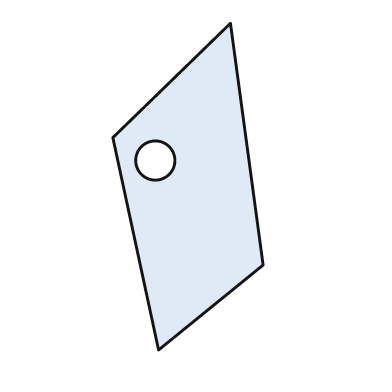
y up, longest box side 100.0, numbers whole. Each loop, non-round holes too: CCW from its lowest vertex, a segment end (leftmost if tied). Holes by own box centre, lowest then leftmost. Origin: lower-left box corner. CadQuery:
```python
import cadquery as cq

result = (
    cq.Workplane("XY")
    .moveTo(14.0, 0.0)
    .lineTo(46.0, 26.0)
    .lineTo(36.0, 100.0)
    .lineTo(0.0, 65.0)
    .close()
    .moveTo(13.0, 58.0)
    .circle(6.0)
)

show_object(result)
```